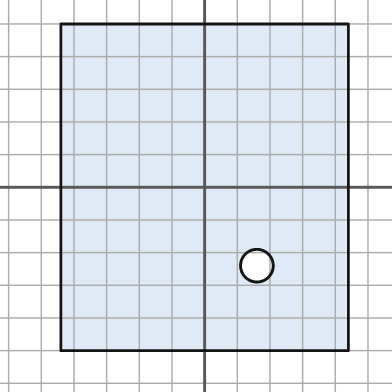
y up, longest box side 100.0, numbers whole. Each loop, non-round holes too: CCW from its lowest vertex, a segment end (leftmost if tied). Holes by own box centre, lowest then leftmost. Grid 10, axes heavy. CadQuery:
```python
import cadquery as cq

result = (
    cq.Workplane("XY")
    .moveTo(-44.0, -50.0)
    .lineTo(44.0, -50.0)
    .lineTo(44.0, 50.0)
    .lineTo(-44.0, 50.0)
    .close()
    .moveTo(16.0, -24.0)
    .circle(5.0)
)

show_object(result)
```